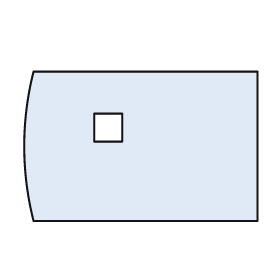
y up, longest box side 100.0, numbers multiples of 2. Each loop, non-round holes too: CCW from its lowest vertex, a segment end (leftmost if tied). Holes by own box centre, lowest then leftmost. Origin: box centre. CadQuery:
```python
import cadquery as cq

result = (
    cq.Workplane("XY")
    .moveTo(-46.0, -32.0)
    .lineTo(50.0, -32.0)
    .lineTo(50.0, 32.0)
    .lineTo(-46.0, 32.0)
    .threePointArc((-50.0, 0.0), (-46.0, -32.0))
    .close()
    .moveTo(-20.0, 2.0)
    .lineTo(-8.0, 2.0)
    .lineTo(-8.0, 14.0)
    .lineTo(-20.0, 14.0)
    .close()
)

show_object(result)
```